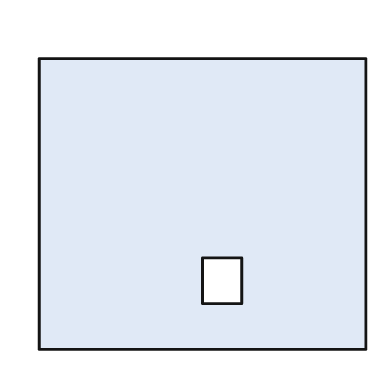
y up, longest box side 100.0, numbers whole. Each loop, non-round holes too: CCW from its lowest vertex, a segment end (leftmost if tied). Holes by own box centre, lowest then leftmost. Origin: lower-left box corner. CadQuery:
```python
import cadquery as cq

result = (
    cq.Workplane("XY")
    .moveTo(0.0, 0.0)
    .lineTo(100.0, 0.0)
    .lineTo(100.0, 89.0)
    .lineTo(0.0, 89.0)
    .close()
    .moveTo(50.0, 14.0)
    .lineTo(62.0, 14.0)
    .lineTo(62.0, 28.0)
    .lineTo(50.0, 28.0)
    .close()
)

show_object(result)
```